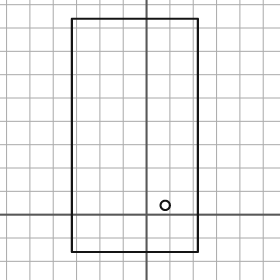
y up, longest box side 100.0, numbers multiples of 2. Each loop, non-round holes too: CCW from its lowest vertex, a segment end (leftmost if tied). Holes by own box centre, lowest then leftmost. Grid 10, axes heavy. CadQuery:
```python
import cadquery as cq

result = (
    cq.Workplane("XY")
    .moveTo(-32.0, -16.0)
    .lineTo(22.0, -16.0)
    .lineTo(22.0, 84.0)
    .lineTo(-32.0, 84.0)
    .close()
    .moveTo(8.0, 4.0)
    .circle(2.0)
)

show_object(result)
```